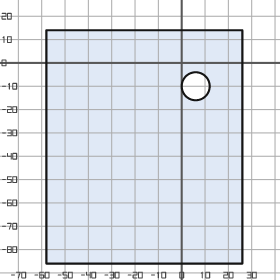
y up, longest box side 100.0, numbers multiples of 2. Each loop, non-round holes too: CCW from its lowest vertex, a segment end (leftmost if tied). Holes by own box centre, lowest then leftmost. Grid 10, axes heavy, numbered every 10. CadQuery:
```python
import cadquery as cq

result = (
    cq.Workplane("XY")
    .moveTo(-58.0, -86.0)
    .lineTo(26.0, -86.0)
    .lineTo(26.0, 14.0)
    .lineTo(-58.0, 14.0)
    .close()
    .moveTo(6.0, -10.0)
    .circle(6.0)
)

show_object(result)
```